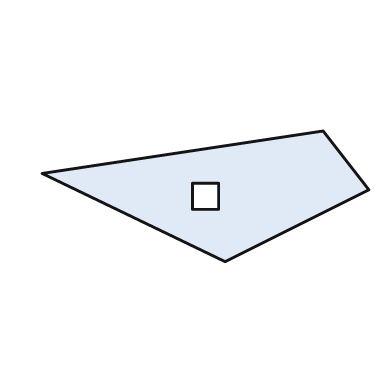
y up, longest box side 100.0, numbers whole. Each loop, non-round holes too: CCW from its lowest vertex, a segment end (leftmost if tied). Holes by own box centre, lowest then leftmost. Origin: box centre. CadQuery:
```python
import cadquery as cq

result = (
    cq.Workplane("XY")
    .moveTo(6.0, -20.0)
    .lineTo(50.0, 2.0)
    .lineTo(36.0, 20.0)
    .lineTo(-50.0, 7.0)
    .close()
    .moveTo(-4.0, -4.0)
    .lineTo(4.0, -4.0)
    .lineTo(4.0, 4.0)
    .lineTo(-4.0, 4.0)
    .close()
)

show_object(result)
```